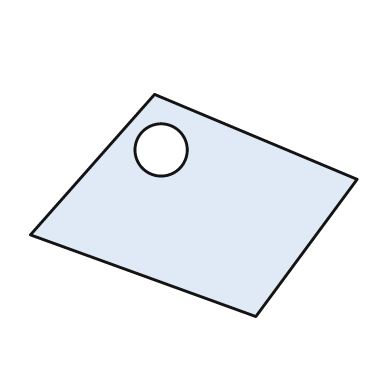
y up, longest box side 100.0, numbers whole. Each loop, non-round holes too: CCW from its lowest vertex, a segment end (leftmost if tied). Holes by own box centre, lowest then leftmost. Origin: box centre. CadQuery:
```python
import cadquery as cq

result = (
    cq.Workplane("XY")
    .moveTo(19.0, -34.0)
    .lineTo(50.0, 8.0)
    .lineTo(-12.0, 34.0)
    .lineTo(-50.0, -9.0)
    .close()
    .moveTo(-10.0, 17.0)
    .circle(8.0)
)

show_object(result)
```